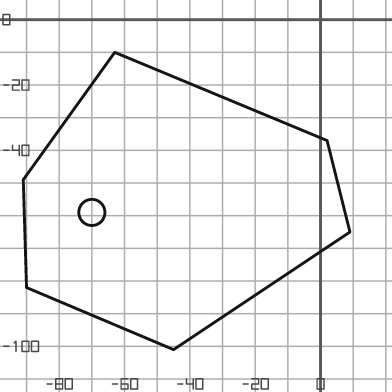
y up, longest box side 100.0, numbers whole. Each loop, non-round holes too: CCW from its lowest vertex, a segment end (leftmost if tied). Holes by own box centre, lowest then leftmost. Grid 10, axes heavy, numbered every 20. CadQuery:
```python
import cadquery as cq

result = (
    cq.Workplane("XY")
    .moveTo(-45.0, -101.0)
    .lineTo(9.0, -65.0)
    .lineTo(2.0, -37.0)
    .lineTo(-63.0, -10.0)
    .lineTo(-91.0, -49.0)
    .lineTo(-90.0, -82.0)
    .close()
    .moveTo(-70.0, -59.0)
    .circle(4.0)
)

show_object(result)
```